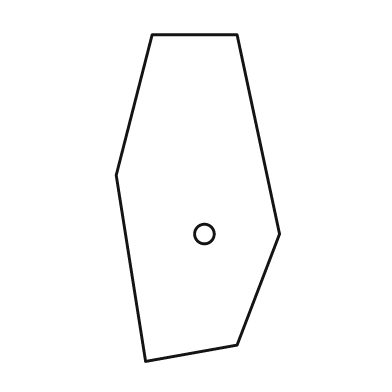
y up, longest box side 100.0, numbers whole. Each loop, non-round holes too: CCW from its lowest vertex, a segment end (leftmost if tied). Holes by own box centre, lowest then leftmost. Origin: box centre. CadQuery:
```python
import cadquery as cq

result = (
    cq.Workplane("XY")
    .moveTo(-16.0, -50.0)
    .lineTo(12.0, -45.0)
    .lineTo(25.0, -11.0)
    .lineTo(12.0, 50.0)
    .lineTo(-14.0, 50.0)
    .lineTo(-25.0, 7.0)
    .close()
    .moveTo(2.0, -11.0)
    .circle(3.0)
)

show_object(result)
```